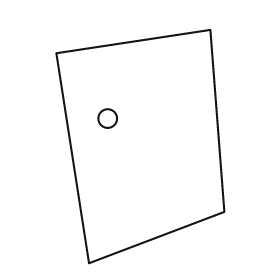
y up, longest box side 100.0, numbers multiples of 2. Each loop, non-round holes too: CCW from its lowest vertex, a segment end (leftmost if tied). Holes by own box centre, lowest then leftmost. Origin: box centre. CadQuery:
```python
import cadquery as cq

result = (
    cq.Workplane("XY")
    .moveTo(-22.0, -50.0)
    .lineTo(36.0, -28.0)
    .lineTo(30.0, 50.0)
    .lineTo(-36.0, 40.0)
    .close()
    .moveTo(-14.0, 12.0)
    .circle(4.0)
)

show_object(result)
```